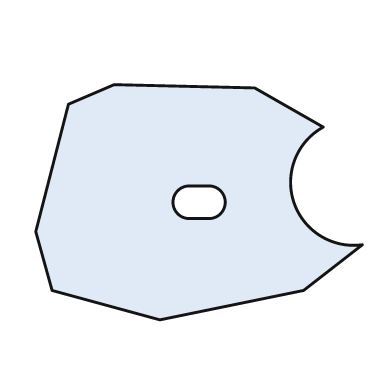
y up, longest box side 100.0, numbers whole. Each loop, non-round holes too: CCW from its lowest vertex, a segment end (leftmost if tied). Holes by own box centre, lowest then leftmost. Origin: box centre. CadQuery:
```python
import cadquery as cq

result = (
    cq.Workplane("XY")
    .moveTo(-12.0, -36.0)
    .lineTo(32.0, -27.0)
    .lineTo(50.0, -13.0)
    .threePointArc((29.0, 0.0), (38.0, 23.0))
    .lineTo(17.0, 35.0)
    .lineTo(-26.0, 36.0)
    .lineTo(-40.0, 30.0)
    .lineTo(-50.0, -9.0)
    .lineTo(-45.0, -27.0)
    .close()
    .moveTo(-3.0, -5.0)
    .lineTo(3.0, -5.0)
    .threePointArc((8.0, 0.0), (3.0, 5.0))
    .lineTo(-3.0, 5.0)
    .threePointArc((-8.0, 0.0), (-3.0, -5.0))
    .close()
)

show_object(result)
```